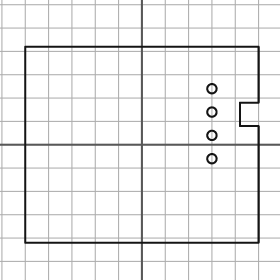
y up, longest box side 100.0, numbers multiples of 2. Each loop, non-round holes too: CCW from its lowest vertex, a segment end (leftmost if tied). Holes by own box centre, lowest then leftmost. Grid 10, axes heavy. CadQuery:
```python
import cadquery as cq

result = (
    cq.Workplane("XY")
    .moveTo(-50.0, -42.0)
    .lineTo(50.0, -42.0)
    .lineTo(50.0, 8.0)
    .lineTo(42.0, 8.0)
    .lineTo(42.0, 18.0)
    .lineTo(50.0, 18.0)
    .lineTo(50.0, 42.0)
    .lineTo(-50.0, 42.0)
    .close()
    .moveTo(30.0, -6.0)
    .circle(2.0)
    .moveTo(30.0, 4.0)
    .circle(2.0)
    .moveTo(30.0, 14.0)
    .circle(2.0)
    .moveTo(30.0, 24.0)
    .circle(2.0)
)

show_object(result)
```